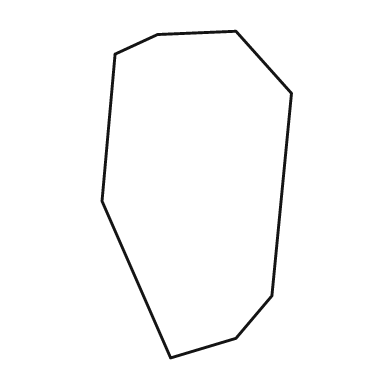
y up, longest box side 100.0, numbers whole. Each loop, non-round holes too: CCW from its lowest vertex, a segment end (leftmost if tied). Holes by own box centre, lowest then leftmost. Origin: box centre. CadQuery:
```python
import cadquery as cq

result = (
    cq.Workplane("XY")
    .moveTo(-8.0, -50.0)
    .lineTo(12.0, -44.0)
    .lineTo(23.0, -31.0)
    .lineTo(29.0, 31.0)
    .lineTo(12.0, 50.0)
    .lineTo(-12.0, 49.0)
    .lineTo(-25.0, 43.0)
    .lineTo(-29.0, -2.0)
    .close()
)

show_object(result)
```